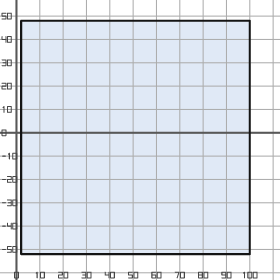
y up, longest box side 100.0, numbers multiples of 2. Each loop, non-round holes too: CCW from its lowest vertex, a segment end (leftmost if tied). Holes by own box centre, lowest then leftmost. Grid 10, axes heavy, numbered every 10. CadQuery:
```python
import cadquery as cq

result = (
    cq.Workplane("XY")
    .moveTo(2.0, -52.0)
    .lineTo(100.0, -52.0)
    .lineTo(100.0, 48.0)
    .lineTo(2.0, 48.0)
    .close()
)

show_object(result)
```